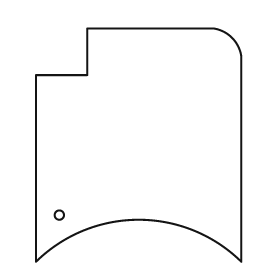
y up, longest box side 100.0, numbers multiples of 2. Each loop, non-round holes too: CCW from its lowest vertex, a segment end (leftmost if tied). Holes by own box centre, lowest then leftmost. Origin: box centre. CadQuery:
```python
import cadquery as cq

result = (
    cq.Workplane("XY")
    .moveTo(-44.0, -50.0)
    .threePointArc((0.0, -32.0), (44.0, -50.0))
    .lineTo(44.0, 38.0)
    .threePointArc((40.0, 46.0), (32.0, 50.0))
    .lineTo(-22.0, 50.0)
    .lineTo(-22.0, 30.0)
    .lineTo(-44.0, 30.0)
    .close()
    .moveTo(-34.0, -30.0)
    .circle(2.0)
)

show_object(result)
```